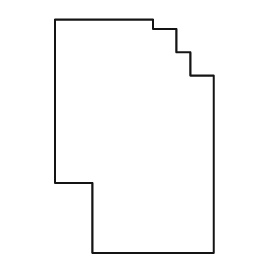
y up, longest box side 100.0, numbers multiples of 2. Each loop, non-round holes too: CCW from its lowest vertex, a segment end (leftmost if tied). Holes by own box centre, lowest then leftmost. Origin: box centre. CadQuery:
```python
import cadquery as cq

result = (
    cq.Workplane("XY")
    .moveTo(-18.0, -50.0)
    .lineTo(34.0, -50.0)
    .lineTo(34.0, 26.0)
    .lineTo(24.0, 26.0)
    .lineTo(24.0, 36.0)
    .lineTo(18.0, 36.0)
    .lineTo(18.0, 46.0)
    .lineTo(8.0, 46.0)
    .lineTo(8.0, 50.0)
    .lineTo(-34.0, 50.0)
    .lineTo(-34.0, -20.0)
    .lineTo(-18.0, -20.0)
    .close()
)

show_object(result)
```